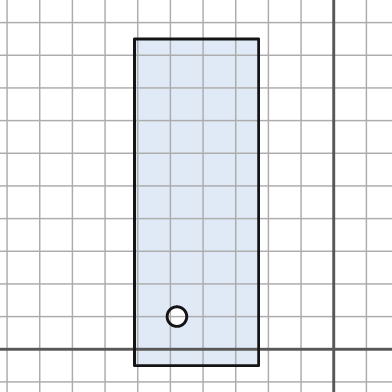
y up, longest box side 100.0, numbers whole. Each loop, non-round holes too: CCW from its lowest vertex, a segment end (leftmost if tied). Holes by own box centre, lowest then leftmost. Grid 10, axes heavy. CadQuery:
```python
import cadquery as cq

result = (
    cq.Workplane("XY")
    .moveTo(-61.0, -5.0)
    .lineTo(-23.0, -5.0)
    .lineTo(-23.0, 95.0)
    .lineTo(-61.0, 95.0)
    .close()
    .moveTo(-48.0, 10.0)
    .circle(3.0)
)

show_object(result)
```